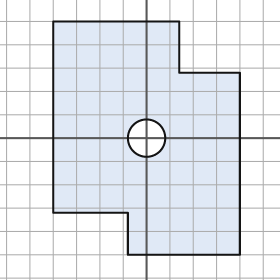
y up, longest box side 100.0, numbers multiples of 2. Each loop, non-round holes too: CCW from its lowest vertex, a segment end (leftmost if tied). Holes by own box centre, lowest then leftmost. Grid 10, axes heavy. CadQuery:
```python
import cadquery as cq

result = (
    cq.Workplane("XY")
    .moveTo(-8.0, -50.0)
    .lineTo(40.0, -50.0)
    .lineTo(40.0, 28.0)
    .lineTo(14.0, 28.0)
    .lineTo(14.0, 50.0)
    .lineTo(-40.0, 50.0)
    .lineTo(-40.0, -32.0)
    .lineTo(-8.0, -32.0)
    .close()
    .moveTo(0.0, 0.0)
    .circle(8.0)
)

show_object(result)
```